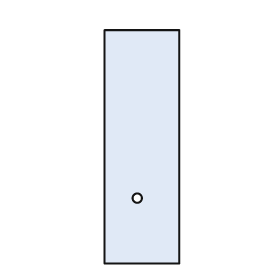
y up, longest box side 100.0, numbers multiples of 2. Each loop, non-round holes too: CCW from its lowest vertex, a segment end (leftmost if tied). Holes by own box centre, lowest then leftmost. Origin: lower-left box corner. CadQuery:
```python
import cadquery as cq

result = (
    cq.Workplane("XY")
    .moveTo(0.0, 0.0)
    .lineTo(32.0, 0.0)
    .lineTo(32.0, 100.0)
    .lineTo(0.0, 100.0)
    .close()
    .moveTo(14.0, 28.0)
    .circle(2.0)
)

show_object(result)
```